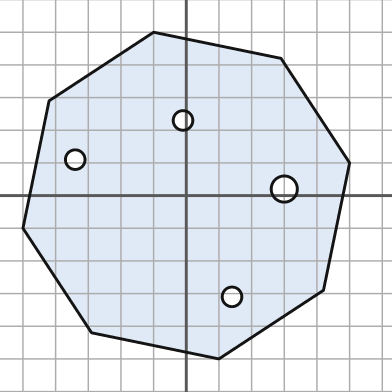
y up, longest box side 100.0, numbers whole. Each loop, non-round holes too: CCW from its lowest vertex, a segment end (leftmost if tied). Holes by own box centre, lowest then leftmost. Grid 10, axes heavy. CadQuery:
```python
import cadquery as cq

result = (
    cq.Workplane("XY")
    .moveTo(10.0, -50.0)
    .lineTo(42.0, -29.0)
    .lineTo(50.0, 10.0)
    .lineTo(29.0, 42.0)
    .lineTo(-10.0, 50.0)
    .lineTo(-42.0, 29.0)
    .lineTo(-50.0, -10.0)
    .lineTo(-29.0, -42.0)
    .close()
    .moveTo(14.0, -31.0)
    .circle(3.0)
    .moveTo(30.0, 2.0)
    .circle(4.0)
    .moveTo(-34.0, 11.0)
    .circle(3.0)
    .moveTo(-1.0, 23.0)
    .circle(3.0)
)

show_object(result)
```